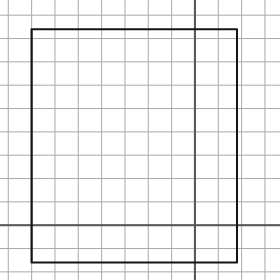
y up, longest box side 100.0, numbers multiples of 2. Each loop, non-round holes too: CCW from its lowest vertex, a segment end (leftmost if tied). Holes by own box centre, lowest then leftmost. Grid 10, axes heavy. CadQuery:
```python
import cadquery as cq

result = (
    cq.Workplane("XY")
    .moveTo(-70.0, -16.0)
    .lineTo(18.0, -16.0)
    .lineTo(18.0, 84.0)
    .lineTo(-70.0, 84.0)
    .close()
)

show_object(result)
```